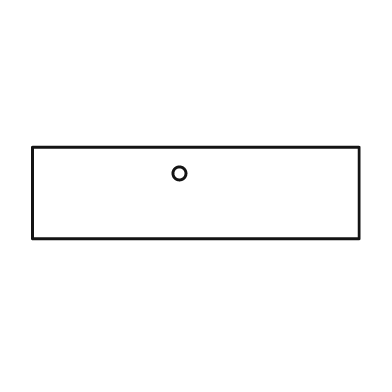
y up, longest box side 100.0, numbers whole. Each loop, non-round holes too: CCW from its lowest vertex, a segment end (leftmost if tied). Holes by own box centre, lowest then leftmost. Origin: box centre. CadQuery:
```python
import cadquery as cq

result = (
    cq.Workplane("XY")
    .moveTo(-50.0, -14.0)
    .lineTo(50.0, -14.0)
    .lineTo(50.0, 14.0)
    .lineTo(-50.0, 14.0)
    .close()
    .moveTo(-5.0, 6.0)
    .circle(2.0)
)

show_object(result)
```